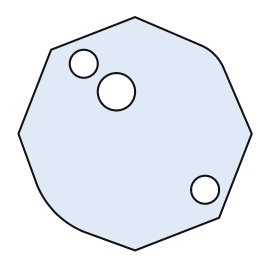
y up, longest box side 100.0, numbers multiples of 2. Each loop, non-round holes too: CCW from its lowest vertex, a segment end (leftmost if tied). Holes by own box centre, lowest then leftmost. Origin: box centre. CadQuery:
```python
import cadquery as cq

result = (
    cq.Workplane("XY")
    .moveTo(0.0, -50.0)
    .lineTo(36.0, -36.0)
    .lineTo(50.0, 0.0)
    .lineTo(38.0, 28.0)
    .threePointArc((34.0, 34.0), (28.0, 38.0))
    .lineTo(0.0, 50.0)
    .lineTo(-36.0, 36.0)
    .lineTo(-50.0, 0.0)
    .lineTo(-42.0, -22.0)
    .threePointArc((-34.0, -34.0), (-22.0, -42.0))
    .close()
    .moveTo(30.0, -24.0)
    .circle(6.0)
    .moveTo(-8.0, 18.0)
    .circle(8.0)
    .moveTo(-22.0, 30.0)
    .circle(6.0)
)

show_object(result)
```